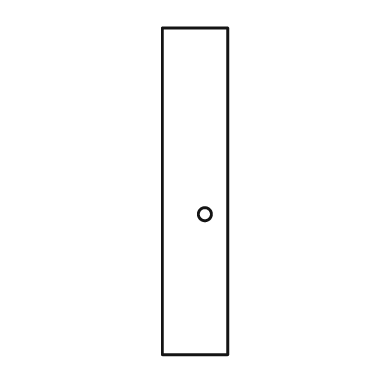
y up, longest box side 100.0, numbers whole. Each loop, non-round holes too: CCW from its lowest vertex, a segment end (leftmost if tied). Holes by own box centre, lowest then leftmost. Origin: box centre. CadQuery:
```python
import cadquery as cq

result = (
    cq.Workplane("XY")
    .moveTo(-10.0, -50.0)
    .lineTo(10.0, -50.0)
    .lineTo(10.0, 50.0)
    .lineTo(-10.0, 50.0)
    .close()
    .moveTo(3.0, -7.0)
    .circle(2.0)
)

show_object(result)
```